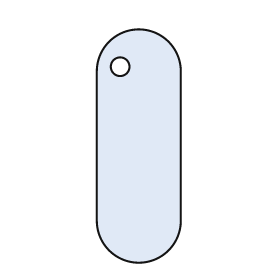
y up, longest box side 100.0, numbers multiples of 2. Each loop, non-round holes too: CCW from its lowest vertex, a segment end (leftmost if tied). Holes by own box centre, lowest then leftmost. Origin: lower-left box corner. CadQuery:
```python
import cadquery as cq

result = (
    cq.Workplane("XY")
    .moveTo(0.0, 18.0)
    .threePointArc((18.0, 0.0), (36.0, 18.0))
    .lineTo(36.0, 82.0)
    .threePointArc((18.0, 100.0), (0.0, 82.0))
    .close()
    .moveTo(10.0, 84.0)
    .circle(4.0)
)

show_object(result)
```